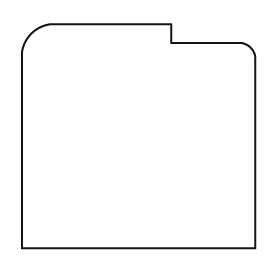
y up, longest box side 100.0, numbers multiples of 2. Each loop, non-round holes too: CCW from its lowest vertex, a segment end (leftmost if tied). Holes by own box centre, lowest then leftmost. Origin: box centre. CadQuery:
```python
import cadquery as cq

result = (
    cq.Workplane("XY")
    .moveTo(-50.0, -48.0)
    .lineTo(50.0, -48.0)
    .lineTo(50.0, 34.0)
    .threePointArc((48.0, 38.0), (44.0, 40.0))
    .lineTo(14.0, 40.0)
    .lineTo(14.0, 48.0)
    .lineTo(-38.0, 48.0)
    .threePointArc((-46.0, 44.0), (-50.0, 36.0))
    .close()
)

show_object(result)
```